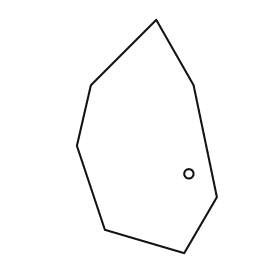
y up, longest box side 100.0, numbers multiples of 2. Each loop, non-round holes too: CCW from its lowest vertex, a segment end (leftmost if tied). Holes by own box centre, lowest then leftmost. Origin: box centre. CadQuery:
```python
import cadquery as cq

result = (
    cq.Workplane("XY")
    .moveTo(16.0, -50.0)
    .lineTo(30.0, -26.0)
    .lineTo(20.0, 22.0)
    .lineTo(4.0, 50.0)
    .lineTo(-24.0, 22.0)
    .lineTo(-30.0, -4.0)
    .lineTo(-18.0, -40.0)
    .close()
    .moveTo(18.0, -16.0)
    .circle(2.0)
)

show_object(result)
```